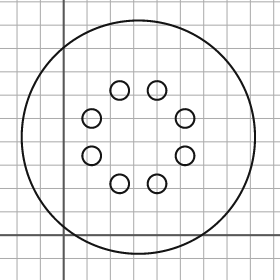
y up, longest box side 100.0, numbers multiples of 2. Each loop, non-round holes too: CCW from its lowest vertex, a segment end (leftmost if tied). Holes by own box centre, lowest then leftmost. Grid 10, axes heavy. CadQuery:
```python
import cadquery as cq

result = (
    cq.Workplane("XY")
    .moveTo(32.0, 42.0)
    .circle(50.0)
    .moveTo(24.0, 22.0)
    .circle(4.0)
    .moveTo(40.0, 22.0)
    .circle(4.0)
    .moveTo(12.0, 34.0)
    .circle(4.0)
    .moveTo(52.0, 34.0)
    .circle(4.0)
    .moveTo(12.0, 50.0)
    .circle(4.0)
    .moveTo(52.0, 50.0)
    .circle(4.0)
    .moveTo(24.0, 62.0)
    .circle(4.0)
    .moveTo(40.0, 62.0)
    .circle(4.0)
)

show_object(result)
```